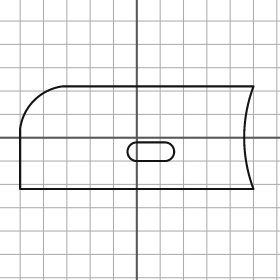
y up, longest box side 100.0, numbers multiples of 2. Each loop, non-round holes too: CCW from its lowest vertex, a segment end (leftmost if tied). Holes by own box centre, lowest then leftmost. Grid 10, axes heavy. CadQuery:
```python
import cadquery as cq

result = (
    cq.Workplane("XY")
    .moveTo(-50.0, -22.0)
    .lineTo(50.0, -22.0)
    .threePointArc((46.0, 0.0), (50.0, 22.0))
    .lineTo(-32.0, 22.0)
    .threePointArc((-44.0, 16.0), (-50.0, 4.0))
    .close()
    .moveTo(0.0, -10.0)
    .lineTo(12.0, -10.0)
    .threePointArc((16.0, -6.0), (12.0, -2.0))
    .lineTo(0.0, -2.0)
    .threePointArc((-4.0, -6.0), (0.0, -10.0))
    .close()
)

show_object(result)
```